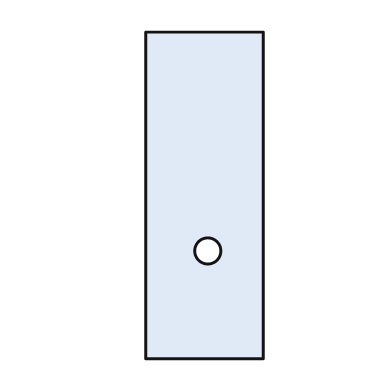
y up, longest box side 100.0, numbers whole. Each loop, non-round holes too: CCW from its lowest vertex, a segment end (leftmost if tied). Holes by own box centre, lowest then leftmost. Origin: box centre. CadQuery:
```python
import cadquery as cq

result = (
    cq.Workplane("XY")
    .moveTo(-18.0, -50.0)
    .lineTo(18.0, -50.0)
    .lineTo(18.0, 50.0)
    .lineTo(-18.0, 50.0)
    .close()
    .moveTo(1.0, -17.0)
    .circle(4.0)
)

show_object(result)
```